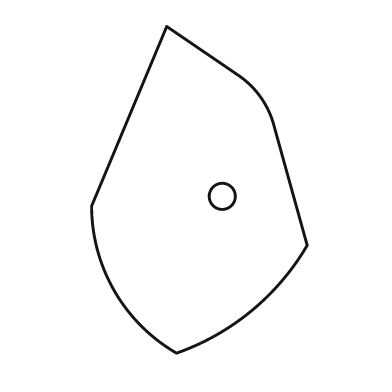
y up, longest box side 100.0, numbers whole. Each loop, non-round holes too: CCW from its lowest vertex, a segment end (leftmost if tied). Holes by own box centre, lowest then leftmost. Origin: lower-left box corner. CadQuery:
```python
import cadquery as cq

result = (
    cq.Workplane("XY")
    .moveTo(26.0, 0.0)
    .threePointArc((49.0, 13.0), (66.0, 33.0))
    .lineTo(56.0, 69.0)
    .threePointArc((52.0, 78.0), (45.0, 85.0))
    .lineTo(23.0, 100.0)
    .lineTo(0.0, 45.0)
    .threePointArc((7.0, 19.0), (26.0, 0.0))
    .close()
    .moveTo(40.0, 48.0)
    .circle(4.0)
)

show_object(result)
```